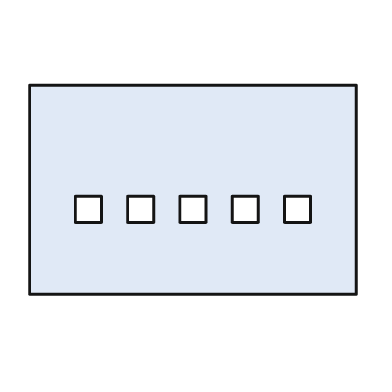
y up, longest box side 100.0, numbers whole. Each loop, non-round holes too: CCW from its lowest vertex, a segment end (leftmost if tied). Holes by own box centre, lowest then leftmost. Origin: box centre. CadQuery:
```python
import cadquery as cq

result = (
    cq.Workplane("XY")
    .moveTo(-50.0, -32.0)
    .lineTo(50.0, -32.0)
    .lineTo(50.0, 32.0)
    .lineTo(-50.0, 32.0)
    .close()
    .moveTo(-36.0, -10.0)
    .lineTo(-28.0, -10.0)
    .lineTo(-28.0, -2.0)
    .lineTo(-36.0, -2.0)
    .close()
    .moveTo(-20.0, -10.0)
    .lineTo(-12.0, -10.0)
    .lineTo(-12.0, -2.0)
    .lineTo(-20.0, -2.0)
    .close()
    .moveTo(-4.0, -10.0)
    .lineTo(4.0, -10.0)
    .lineTo(4.0, -2.0)
    .lineTo(-4.0, -2.0)
    .close()
    .moveTo(12.0, -10.0)
    .lineTo(20.0, -10.0)
    .lineTo(20.0, -2.0)
    .lineTo(12.0, -2.0)
    .close()
    .moveTo(28.0, -10.0)
    .lineTo(36.0, -10.0)
    .lineTo(36.0, -2.0)
    .lineTo(28.0, -2.0)
    .close()
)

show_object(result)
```